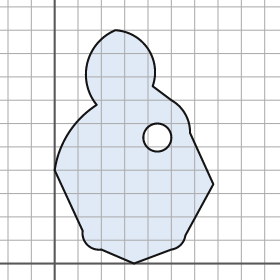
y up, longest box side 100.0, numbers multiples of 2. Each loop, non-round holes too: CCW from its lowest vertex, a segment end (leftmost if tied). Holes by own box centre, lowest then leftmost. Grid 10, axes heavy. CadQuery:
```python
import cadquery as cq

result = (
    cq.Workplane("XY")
    .moveTo(34.0, 0.0)
    .lineTo(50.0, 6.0)
    .threePointArc((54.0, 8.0), (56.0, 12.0))
    .lineTo(68.0, 34.0)
    .lineTo(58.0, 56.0)
    .threePointArc((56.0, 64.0), (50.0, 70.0))
    .lineTo(42.0, 76.0)
    .threePointArc((40.0, 92.0), (26.0, 100.0))
    .threePointArc((14.0, 86.0), (18.0, 68.0))
    .threePointArc((6.0, 56.0), (0.0, 40.0))
    .lineTo(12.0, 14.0)
    .threePointArc((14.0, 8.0), (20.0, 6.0))
    .close()
    .moveTo(44.0, 54.0)
    .circle(6.0)
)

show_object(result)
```